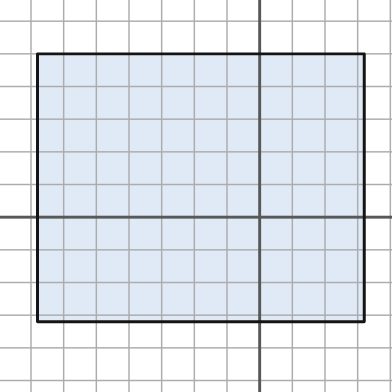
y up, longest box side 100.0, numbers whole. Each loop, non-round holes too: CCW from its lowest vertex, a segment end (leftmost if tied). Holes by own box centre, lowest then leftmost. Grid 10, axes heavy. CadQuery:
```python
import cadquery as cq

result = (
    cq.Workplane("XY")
    .moveTo(-68.0, -32.0)
    .lineTo(32.0, -32.0)
    .lineTo(32.0, 50.0)
    .lineTo(-68.0, 50.0)
    .close()
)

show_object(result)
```